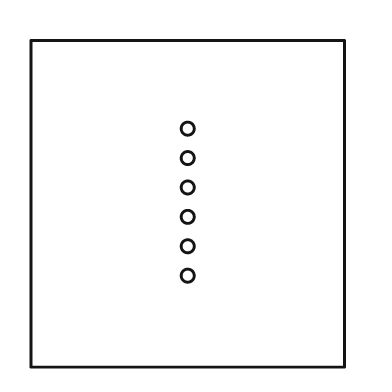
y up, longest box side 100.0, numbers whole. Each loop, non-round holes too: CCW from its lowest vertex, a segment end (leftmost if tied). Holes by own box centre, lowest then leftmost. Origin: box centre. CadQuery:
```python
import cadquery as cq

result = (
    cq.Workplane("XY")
    .moveTo(-48.0, -50.0)
    .lineTo(48.0, -50.0)
    .lineTo(48.0, 50.0)
    .lineTo(-48.0, 50.0)
    .close()
    .moveTo(0.0, -22.0)
    .circle(2.0)
    .moveTo(0.0, -13.0)
    .circle(2.0)
    .moveTo(0.0, -4.0)
    .circle(2.0)
    .moveTo(0.0, 5.0)
    .circle(2.0)
    .moveTo(0.0, 14.0)
    .circle(2.0)
    .moveTo(0.0, 23.0)
    .circle(2.0)
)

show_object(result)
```